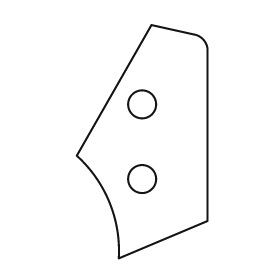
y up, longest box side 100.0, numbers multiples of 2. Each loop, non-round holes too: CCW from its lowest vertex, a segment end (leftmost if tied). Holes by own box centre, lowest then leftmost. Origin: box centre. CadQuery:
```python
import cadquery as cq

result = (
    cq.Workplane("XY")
    .moveTo(-10.0, -50.0)
    .lineTo(28.0, -34.0)
    .lineTo(28.0, 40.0)
    .threePointArc((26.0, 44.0), (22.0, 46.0))
    .lineTo(4.0, 50.0)
    .lineTo(-28.0, -6.0)
    .threePointArc((-14.0, -26.0), (-10.0, -50.0))
    .close()
    .moveTo(0.0, -16.0)
    .circle(6.0)
    .moveTo(0.0, 16.0)
    .circle(6.0)
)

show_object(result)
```